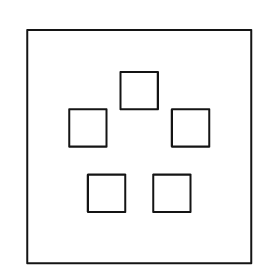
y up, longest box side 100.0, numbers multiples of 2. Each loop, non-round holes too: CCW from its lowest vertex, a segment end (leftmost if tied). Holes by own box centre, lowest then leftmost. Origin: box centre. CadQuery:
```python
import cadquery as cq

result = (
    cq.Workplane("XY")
    .moveTo(-48.0, -50.0)
    .lineTo(48.0, -50.0)
    .lineTo(48.0, 50.0)
    .lineTo(-48.0, 50.0)
    .close()
    .moveTo(-22.0, -28.0)
    .lineTo(-6.0, -28.0)
    .lineTo(-6.0, -12.0)
    .lineTo(-22.0, -12.0)
    .close()
    .moveTo(6.0, -28.0)
    .lineTo(22.0, -28.0)
    .lineTo(22.0, -12.0)
    .lineTo(6.0, -12.0)
    .close()
    .moveTo(-30.0, 0.0)
    .lineTo(-14.0, 0.0)
    .lineTo(-14.0, 16.0)
    .lineTo(-30.0, 16.0)
    .close()
    .moveTo(14.0, 0.0)
    .lineTo(30.0, 0.0)
    .lineTo(30.0, 16.0)
    .lineTo(14.0, 16.0)
    .close()
    .moveTo(-8.0, 16.0)
    .lineTo(8.0, 16.0)
    .lineTo(8.0, 32.0)
    .lineTo(-8.0, 32.0)
    .close()
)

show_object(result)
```